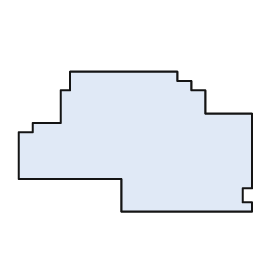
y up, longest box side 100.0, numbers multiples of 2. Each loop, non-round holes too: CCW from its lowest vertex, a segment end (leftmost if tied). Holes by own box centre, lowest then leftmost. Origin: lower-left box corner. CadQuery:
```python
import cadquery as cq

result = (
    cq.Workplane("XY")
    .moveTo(44.0, 0.0)
    .lineTo(100.0, 0.0)
    .lineTo(100.0, 4.0)
    .lineTo(96.0, 4.0)
    .lineTo(96.0, 10.0)
    .lineTo(100.0, 10.0)
    .lineTo(100.0, 42.0)
    .lineTo(80.0, 42.0)
    .lineTo(80.0, 52.0)
    .lineTo(74.0, 52.0)
    .lineTo(74.0, 56.0)
    .lineTo(68.0, 56.0)
    .lineTo(68.0, 60.0)
    .lineTo(22.0, 60.0)
    .lineTo(22.0, 52.0)
    .lineTo(18.0, 52.0)
    .lineTo(18.0, 38.0)
    .lineTo(6.0, 38.0)
    .lineTo(6.0, 34.0)
    .lineTo(0.0, 34.0)
    .lineTo(0.0, 14.0)
    .lineTo(44.0, 14.0)
    .close()
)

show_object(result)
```